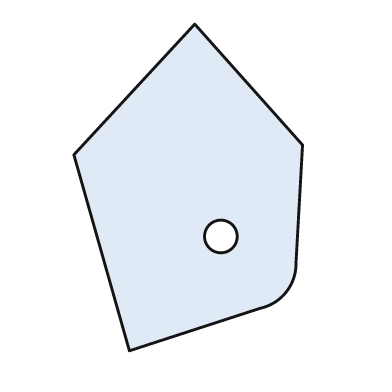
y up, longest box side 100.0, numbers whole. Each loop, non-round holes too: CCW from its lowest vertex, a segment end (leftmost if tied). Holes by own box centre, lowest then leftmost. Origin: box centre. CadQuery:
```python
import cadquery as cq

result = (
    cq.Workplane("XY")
    .moveTo(-18.0, -50.0)
    .lineTo(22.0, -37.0)
    .threePointArc((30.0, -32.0), (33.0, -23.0))
    .lineTo(35.0, 13.0)
    .lineTo(2.0, 50.0)
    .lineTo(-35.0, 10.0)
    .close()
    .moveTo(10.0, -15.0)
    .circle(5.0)
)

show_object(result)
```